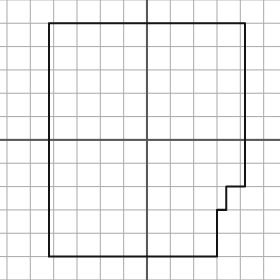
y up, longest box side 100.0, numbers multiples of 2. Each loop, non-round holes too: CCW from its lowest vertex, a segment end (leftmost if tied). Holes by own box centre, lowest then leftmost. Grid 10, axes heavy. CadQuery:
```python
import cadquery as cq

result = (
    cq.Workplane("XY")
    .moveTo(-42.0, -50.0)
    .lineTo(30.0, -50.0)
    .lineTo(30.0, -30.0)
    .lineTo(34.0, -30.0)
    .lineTo(34.0, -20.0)
    .lineTo(42.0, -20.0)
    .lineTo(42.0, 50.0)
    .lineTo(-42.0, 50.0)
    .close()
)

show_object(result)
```